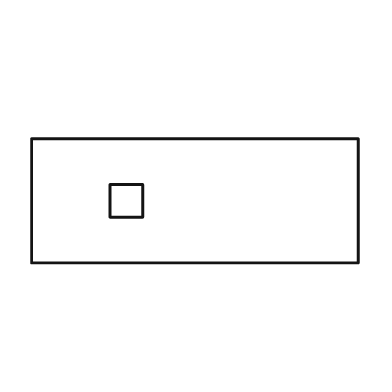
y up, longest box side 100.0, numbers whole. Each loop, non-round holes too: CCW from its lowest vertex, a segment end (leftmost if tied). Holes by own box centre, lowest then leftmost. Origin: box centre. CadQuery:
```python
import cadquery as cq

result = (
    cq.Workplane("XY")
    .moveTo(-50.0, -19.0)
    .lineTo(50.0, -19.0)
    .lineTo(50.0, 19.0)
    .lineTo(-50.0, 19.0)
    .close()
    .moveTo(-26.0, -5.0)
    .lineTo(-16.0, -5.0)
    .lineTo(-16.0, 5.0)
    .lineTo(-26.0, 5.0)
    .close()
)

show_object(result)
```